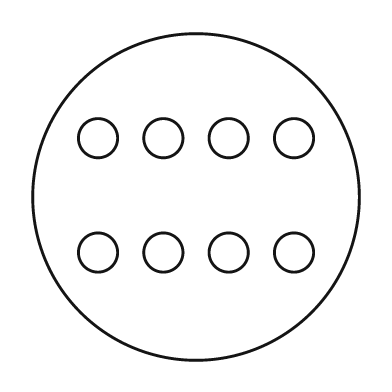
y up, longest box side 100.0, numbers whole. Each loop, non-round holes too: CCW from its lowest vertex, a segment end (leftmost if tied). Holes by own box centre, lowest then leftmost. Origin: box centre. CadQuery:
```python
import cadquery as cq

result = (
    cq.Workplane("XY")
    .moveTo(0.0, 0.0)
    .circle(50.0)
    .moveTo(-30.0, -17.0)
    .circle(6.0)
    .moveTo(-10.0, -17.0)
    .circle(6.0)
    .moveTo(10.0, -17.0)
    .circle(6.0)
    .moveTo(30.0, -17.0)
    .circle(6.0)
    .moveTo(-30.0, 18.0)
    .circle(6.0)
    .moveTo(-10.0, 18.0)
    .circle(6.0)
    .moveTo(10.0, 18.0)
    .circle(6.0)
    .moveTo(30.0, 18.0)
    .circle(6.0)
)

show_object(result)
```